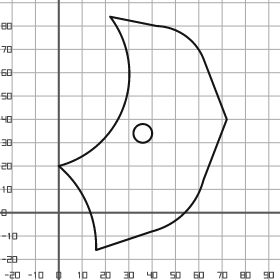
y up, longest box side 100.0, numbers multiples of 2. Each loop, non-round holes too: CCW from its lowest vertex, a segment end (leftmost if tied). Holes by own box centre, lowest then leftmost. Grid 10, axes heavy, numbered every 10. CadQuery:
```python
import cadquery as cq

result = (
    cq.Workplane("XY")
    .moveTo(16.0, -16.0)
    .lineTo(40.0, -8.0)
    .threePointArc((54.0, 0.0), (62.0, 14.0))
    .lineTo(72.0, 40.0)
    .lineTo(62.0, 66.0)
    .threePointArc((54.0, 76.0), (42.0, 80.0))
    .lineTo(22.0, 84.0)
    .threePointArc((28.0, 46.0), (0.0, 20.0))
    .threePointArc((12.0, 4.0), (16.0, -16.0))
    .close()
    .moveTo(36.0, 34.0)
    .circle(4.0)
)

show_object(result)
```